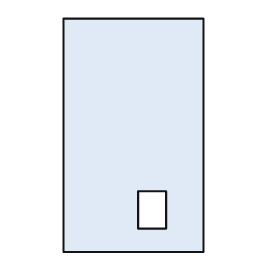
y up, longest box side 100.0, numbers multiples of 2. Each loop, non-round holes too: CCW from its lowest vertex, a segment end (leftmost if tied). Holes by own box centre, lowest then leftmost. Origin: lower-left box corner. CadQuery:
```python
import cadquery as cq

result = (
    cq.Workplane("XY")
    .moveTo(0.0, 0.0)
    .lineTo(60.0, 0.0)
    .lineTo(60.0, 100.0)
    .lineTo(0.0, 100.0)
    .close()
    .moveTo(32.0, 10.0)
    .lineTo(44.0, 10.0)
    .lineTo(44.0, 26.0)
    .lineTo(32.0, 26.0)
    .close()
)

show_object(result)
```